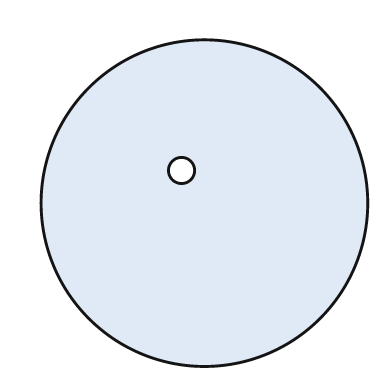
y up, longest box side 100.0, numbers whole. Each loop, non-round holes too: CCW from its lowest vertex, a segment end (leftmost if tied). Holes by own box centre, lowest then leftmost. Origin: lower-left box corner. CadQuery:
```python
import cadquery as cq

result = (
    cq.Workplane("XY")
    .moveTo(50.0, 50.0)
    .circle(50.0)
    .moveTo(43.0, 60.0)
    .circle(4.0)
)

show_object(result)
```